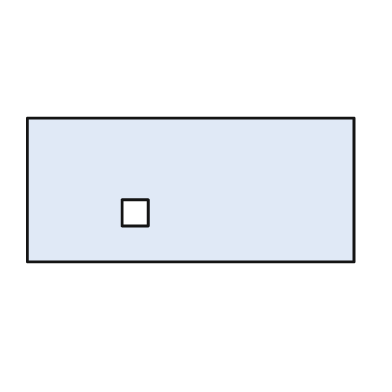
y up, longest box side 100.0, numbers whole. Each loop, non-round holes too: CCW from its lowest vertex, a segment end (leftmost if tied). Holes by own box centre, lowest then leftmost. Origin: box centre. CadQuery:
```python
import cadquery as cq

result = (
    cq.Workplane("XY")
    .moveTo(-50.0, -22.0)
    .lineTo(50.0, -22.0)
    .lineTo(50.0, 22.0)
    .lineTo(-50.0, 22.0)
    .close()
    .moveTo(-21.0, -11.0)
    .lineTo(-13.0, -11.0)
    .lineTo(-13.0, -3.0)
    .lineTo(-21.0, -3.0)
    .close()
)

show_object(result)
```